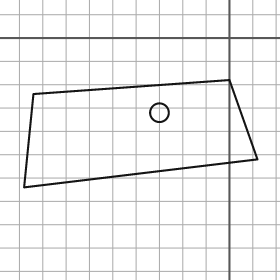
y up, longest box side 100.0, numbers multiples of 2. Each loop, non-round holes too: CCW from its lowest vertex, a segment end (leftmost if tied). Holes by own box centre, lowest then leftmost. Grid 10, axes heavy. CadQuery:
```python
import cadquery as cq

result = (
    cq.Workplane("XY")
    .moveTo(-88.0, -64.0)
    .lineTo(12.0, -52.0)
    .lineTo(0.0, -18.0)
    .lineTo(-84.0, -24.0)
    .close()
    .moveTo(-30.0, -32.0)
    .circle(4.0)
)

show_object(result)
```